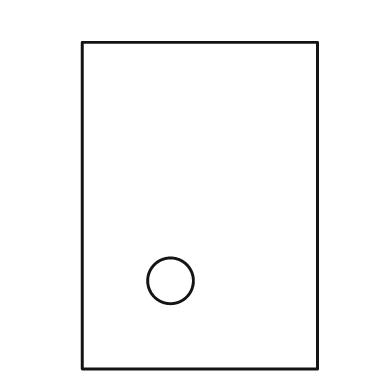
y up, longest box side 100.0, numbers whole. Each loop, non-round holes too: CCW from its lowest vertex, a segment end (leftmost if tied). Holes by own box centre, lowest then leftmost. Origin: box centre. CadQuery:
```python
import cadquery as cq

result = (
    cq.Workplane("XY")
    .moveTo(-36.0, -50.0)
    .lineTo(36.0, -50.0)
    .lineTo(36.0, 50.0)
    .lineTo(-36.0, 50.0)
    .close()
    .moveTo(-9.0, -23.0)
    .circle(7.0)
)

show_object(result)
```